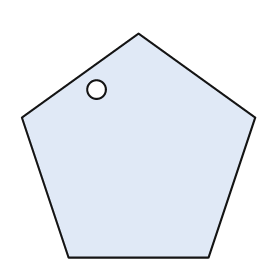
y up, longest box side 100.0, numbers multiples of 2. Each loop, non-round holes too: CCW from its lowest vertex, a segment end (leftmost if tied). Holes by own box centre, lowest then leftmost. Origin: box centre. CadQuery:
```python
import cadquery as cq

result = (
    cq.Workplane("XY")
    .moveTo(-30.0, -48.0)
    .lineTo(30.0, -48.0)
    .lineTo(50.0, 12.0)
    .lineTo(0.0, 48.0)
    .lineTo(-50.0, 12.0)
    .close()
    .moveTo(-18.0, 24.0)
    .circle(4.0)
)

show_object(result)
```